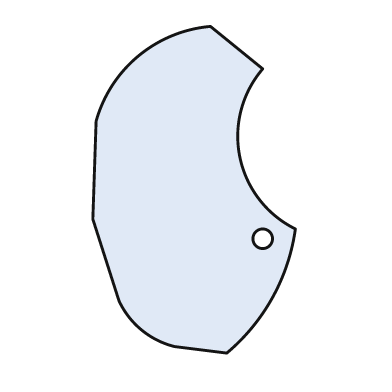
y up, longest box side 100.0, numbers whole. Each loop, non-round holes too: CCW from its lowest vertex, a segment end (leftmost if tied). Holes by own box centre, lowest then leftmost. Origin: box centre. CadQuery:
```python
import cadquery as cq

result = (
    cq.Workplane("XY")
    .moveTo(10.0, -50.0)
    .threePointArc((24.0, -33.0), (31.0, -12.0))
    .threePointArc((14.0, 10.0), (21.0, 37.0))
    .lineTo(5.0, 50.0)
    .threePointArc((-17.0, 41.0), (-30.0, 21.0))
    .lineTo(-31.0, -9.0)
    .lineTo(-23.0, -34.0)
    .threePointArc((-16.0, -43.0), (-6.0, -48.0))
    .close()
    .moveTo(21.0, -15.0)
    .circle(3.0)
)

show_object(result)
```